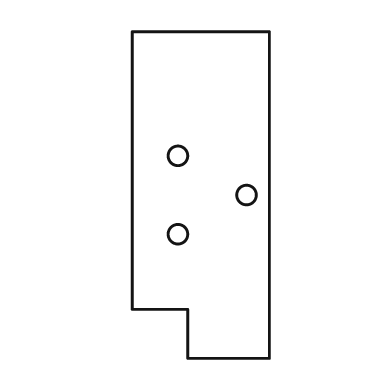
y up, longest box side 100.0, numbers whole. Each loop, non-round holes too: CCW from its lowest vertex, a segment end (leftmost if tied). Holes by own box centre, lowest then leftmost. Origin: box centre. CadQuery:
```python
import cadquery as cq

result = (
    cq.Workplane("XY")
    .moveTo(-4.0, -50.0)
    .lineTo(21.0, -50.0)
    .lineTo(21.0, 50.0)
    .lineTo(-21.0, 50.0)
    .lineTo(-21.0, -35.0)
    .lineTo(-4.0, -35.0)
    .close()
    .moveTo(-7.0, -12.0)
    .circle(3.0)
    .moveTo(14.0, 0.0)
    .circle(3.0)
    .moveTo(-7.0, 12.0)
    .circle(3.0)
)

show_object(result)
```